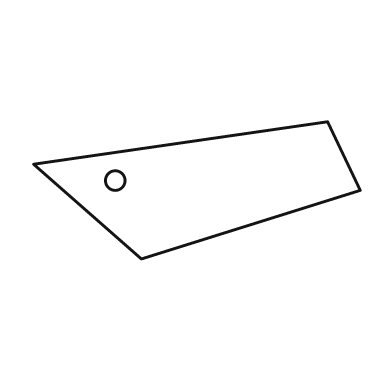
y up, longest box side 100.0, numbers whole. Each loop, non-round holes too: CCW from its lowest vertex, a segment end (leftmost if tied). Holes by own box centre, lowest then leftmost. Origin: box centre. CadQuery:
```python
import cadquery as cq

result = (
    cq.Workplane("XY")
    .moveTo(-17.0, -21.0)
    .lineTo(50.0, 0.0)
    .lineTo(40.0, 21.0)
    .lineTo(-50.0, 8.0)
    .close()
    .moveTo(-25.0, 3.0)
    .circle(3.0)
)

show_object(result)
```